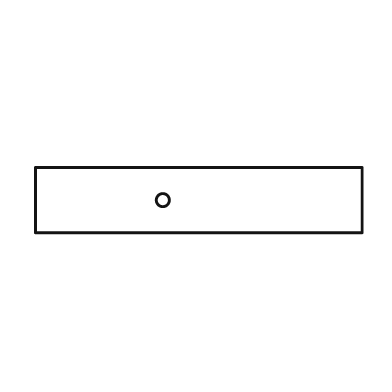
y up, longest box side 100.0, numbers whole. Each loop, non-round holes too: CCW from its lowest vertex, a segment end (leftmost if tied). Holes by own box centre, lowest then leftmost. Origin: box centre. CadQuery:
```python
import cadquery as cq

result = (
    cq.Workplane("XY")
    .moveTo(-50.0, -10.0)
    .lineTo(50.0, -10.0)
    .lineTo(50.0, 10.0)
    .lineTo(-50.0, 10.0)
    .close()
    .moveTo(-11.0, 0.0)
    .circle(2.0)
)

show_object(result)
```